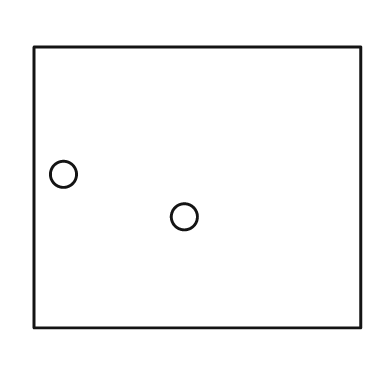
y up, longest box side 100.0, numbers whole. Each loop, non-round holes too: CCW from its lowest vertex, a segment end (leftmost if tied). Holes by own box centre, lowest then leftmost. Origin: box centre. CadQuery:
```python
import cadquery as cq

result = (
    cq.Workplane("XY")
    .moveTo(-50.0, -43.0)
    .lineTo(50.0, -43.0)
    .lineTo(50.0, 43.0)
    .lineTo(-50.0, 43.0)
    .close()
    .moveTo(-4.0, -9.0)
    .circle(4.0)
    .moveTo(-41.0, 4.0)
    .circle(4.0)
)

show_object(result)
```